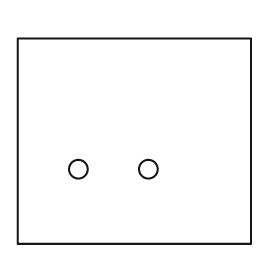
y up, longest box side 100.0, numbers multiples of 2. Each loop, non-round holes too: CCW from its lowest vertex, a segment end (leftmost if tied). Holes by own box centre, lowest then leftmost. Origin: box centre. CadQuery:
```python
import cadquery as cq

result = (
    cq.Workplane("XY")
    .moveTo(-50.0, -44.0)
    .lineTo(50.0, -44.0)
    .lineTo(50.0, 44.0)
    .lineTo(-50.0, 44.0)
    .close()
    .moveTo(-24.0, -12.0)
    .circle(4.0)
    .moveTo(6.0, -12.0)
    .circle(4.0)
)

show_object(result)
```